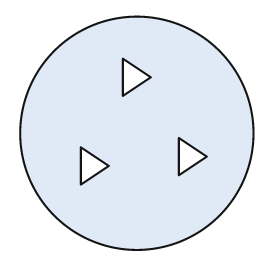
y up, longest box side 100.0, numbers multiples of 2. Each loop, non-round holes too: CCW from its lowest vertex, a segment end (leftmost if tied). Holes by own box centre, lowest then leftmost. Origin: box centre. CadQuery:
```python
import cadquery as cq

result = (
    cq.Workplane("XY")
    .moveTo(0.0, 0.0)
    .circle(50.0)
    .moveTo(-24.0, -22.0)
    .lineTo(-12.0, -14.0)
    .lineTo(-24.0, -6.0)
    .close()
    .moveTo(18.0, -18.0)
    .lineTo(30.0, -10.0)
    .lineTo(18.0, -2.0)
    .close()
    .moveTo(-6.0, 16.0)
    .lineTo(6.0, 24.0)
    .lineTo(-6.0, 32.0)
    .close()
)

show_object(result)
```